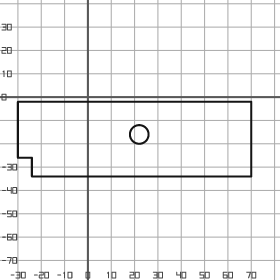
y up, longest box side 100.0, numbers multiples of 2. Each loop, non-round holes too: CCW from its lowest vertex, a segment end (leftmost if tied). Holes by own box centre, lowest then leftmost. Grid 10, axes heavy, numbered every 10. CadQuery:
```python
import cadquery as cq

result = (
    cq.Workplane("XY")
    .moveTo(-24.0, -34.0)
    .lineTo(70.0, -34.0)
    .lineTo(70.0, -2.0)
    .lineTo(-30.0, -2.0)
    .lineTo(-30.0, -26.0)
    .lineTo(-24.0, -26.0)
    .close()
    .moveTo(22.0, -16.0)
    .circle(4.0)
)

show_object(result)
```